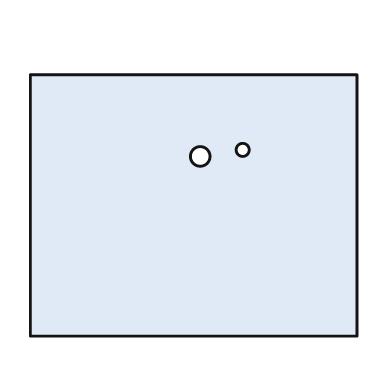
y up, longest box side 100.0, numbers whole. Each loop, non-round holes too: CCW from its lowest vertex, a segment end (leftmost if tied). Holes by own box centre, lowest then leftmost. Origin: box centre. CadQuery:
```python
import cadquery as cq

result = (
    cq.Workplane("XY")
    .moveTo(-50.0, -40.0)
    .lineTo(50.0, -40.0)
    .lineTo(50.0, 40.0)
    .lineTo(-50.0, 40.0)
    .close()
    .moveTo(2.0, 15.0)
    .circle(3.0)
    .moveTo(15.0, 17.0)
    .circle(2.0)
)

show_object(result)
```